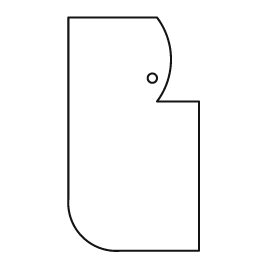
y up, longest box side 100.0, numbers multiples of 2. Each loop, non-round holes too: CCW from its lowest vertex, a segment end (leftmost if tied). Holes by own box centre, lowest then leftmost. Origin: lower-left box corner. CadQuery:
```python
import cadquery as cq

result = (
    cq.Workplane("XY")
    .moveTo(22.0, 0.0)
    .lineTo(56.0, 0.0)
    .lineTo(56.0, 64.0)
    .lineTo(38.0, 64.0)
    .threePointArc((44.0, 82.0), (38.0, 100.0))
    .lineTo(0.0, 100.0)
    .lineTo(0.0, 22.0)
    .threePointArc((6.0, 6.0), (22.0, 0.0))
    .close()
    .moveTo(36.0, 74.0)
    .circle(2.0)
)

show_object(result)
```